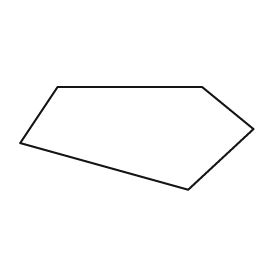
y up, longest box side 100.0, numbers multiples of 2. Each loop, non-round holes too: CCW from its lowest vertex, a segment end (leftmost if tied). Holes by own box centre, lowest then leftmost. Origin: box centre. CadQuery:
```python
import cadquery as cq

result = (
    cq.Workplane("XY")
    .moveTo(22.0, -22.0)
    .lineTo(50.0, 4.0)
    .lineTo(28.0, 22.0)
    .lineTo(-34.0, 22.0)
    .lineTo(-50.0, -2.0)
    .close()
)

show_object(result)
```